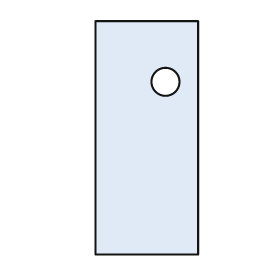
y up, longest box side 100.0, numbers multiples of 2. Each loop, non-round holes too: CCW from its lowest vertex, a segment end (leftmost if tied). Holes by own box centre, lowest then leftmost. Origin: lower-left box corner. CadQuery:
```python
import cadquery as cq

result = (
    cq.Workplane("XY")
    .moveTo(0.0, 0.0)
    .lineTo(44.0, 0.0)
    .lineTo(44.0, 100.0)
    .lineTo(0.0, 100.0)
    .close()
    .moveTo(30.0, 74.0)
    .circle(6.0)
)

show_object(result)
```